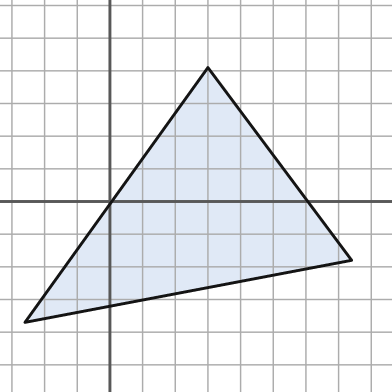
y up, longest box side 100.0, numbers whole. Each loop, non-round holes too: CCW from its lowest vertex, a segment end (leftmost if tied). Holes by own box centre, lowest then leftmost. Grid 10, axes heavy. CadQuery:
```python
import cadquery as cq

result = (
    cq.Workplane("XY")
    .moveTo(-26.0, -37.0)
    .lineTo(74.0, -18.0)
    .lineTo(30.0, 41.0)
    .close()
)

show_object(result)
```